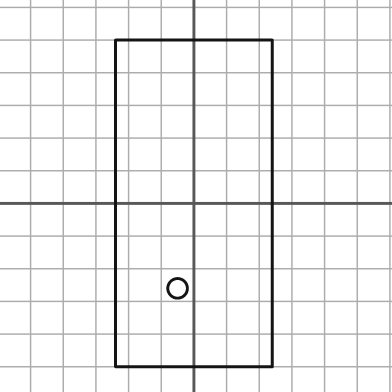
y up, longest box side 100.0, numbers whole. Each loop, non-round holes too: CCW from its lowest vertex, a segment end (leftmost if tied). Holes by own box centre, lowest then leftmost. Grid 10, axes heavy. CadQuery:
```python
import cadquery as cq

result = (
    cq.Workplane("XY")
    .moveTo(-24.0, -50.0)
    .lineTo(24.0, -50.0)
    .lineTo(24.0, 50.0)
    .lineTo(-24.0, 50.0)
    .close()
    .moveTo(-5.0, -26.0)
    .circle(3.0)
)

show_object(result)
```